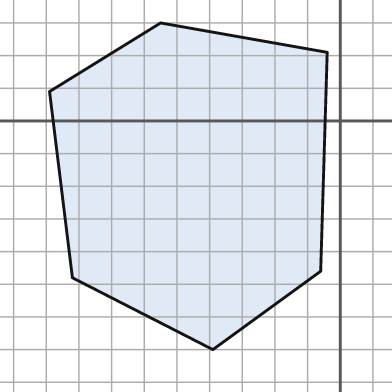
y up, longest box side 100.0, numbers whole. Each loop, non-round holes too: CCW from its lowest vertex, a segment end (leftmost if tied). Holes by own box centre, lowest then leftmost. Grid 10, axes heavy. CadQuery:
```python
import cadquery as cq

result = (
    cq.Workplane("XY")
    .moveTo(-39.0, -70.0)
    .lineTo(-6.0, -46.0)
    .lineTo(-4.0, 21.0)
    .lineTo(-55.0, 30.0)
    .lineTo(-89.0, 9.0)
    .lineTo(-82.0, -48.0)
    .close()
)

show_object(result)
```